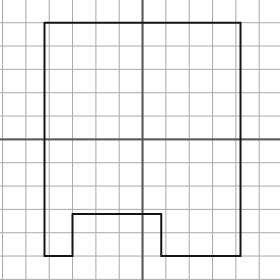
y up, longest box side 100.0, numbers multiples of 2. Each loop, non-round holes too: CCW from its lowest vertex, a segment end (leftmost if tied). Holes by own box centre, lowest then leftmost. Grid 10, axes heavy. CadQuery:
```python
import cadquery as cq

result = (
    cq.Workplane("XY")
    .moveTo(-42.0, -50.0)
    .lineTo(-30.0, -50.0)
    .lineTo(-30.0, -32.0)
    .lineTo(8.0, -32.0)
    .lineTo(8.0, -50.0)
    .lineTo(42.0, -50.0)
    .lineTo(42.0, 50.0)
    .lineTo(-42.0, 50.0)
    .close()
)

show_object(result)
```